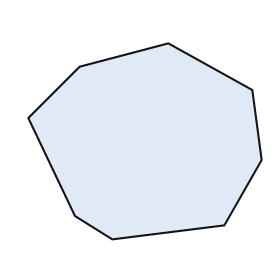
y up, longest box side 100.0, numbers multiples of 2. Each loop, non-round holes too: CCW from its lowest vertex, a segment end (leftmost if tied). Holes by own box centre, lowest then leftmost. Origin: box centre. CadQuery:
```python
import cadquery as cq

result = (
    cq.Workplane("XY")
    .moveTo(-14.0, -42.0)
    .lineTo(34.0, -36.0)
    .lineTo(50.0, -8.0)
    .lineTo(46.0, 22.0)
    .lineTo(10.0, 42.0)
    .lineTo(-28.0, 32.0)
    .lineTo(-50.0, 10.0)
    .lineTo(-30.0, -32.0)
    .close()
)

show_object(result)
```